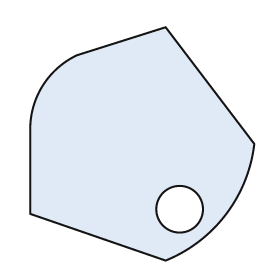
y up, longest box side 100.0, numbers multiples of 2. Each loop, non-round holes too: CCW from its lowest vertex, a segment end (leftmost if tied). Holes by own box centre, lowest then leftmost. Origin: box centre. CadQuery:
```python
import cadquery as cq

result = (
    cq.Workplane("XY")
    .moveTo(10.0, -50.0)
    .threePointArc((36.0, -30.0), (48.0, 0.0))
    .lineTo(10.0, 50.0)
    .lineTo(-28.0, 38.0)
    .threePointArc((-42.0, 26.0), (-48.0, 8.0))
    .lineTo(-48.0, -30.0)
    .close()
    .moveTo(16.0, -28.0)
    .circle(10.0)
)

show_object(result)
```